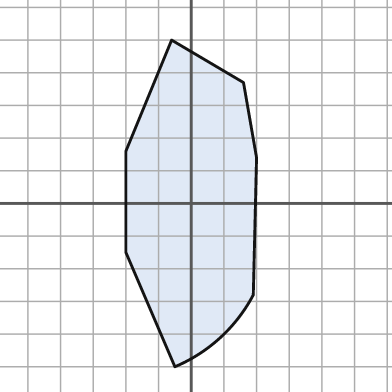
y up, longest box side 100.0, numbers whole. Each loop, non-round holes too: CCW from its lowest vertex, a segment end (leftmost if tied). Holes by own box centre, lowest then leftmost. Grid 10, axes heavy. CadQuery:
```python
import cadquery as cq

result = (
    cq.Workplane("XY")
    .moveTo(-5.0, -50.0)
    .threePointArc((9.0, -41.0), (19.0, -28.0))
    .lineTo(20.0, 14.0)
    .lineTo(16.0, 37.0)
    .lineTo(-6.0, 50.0)
    .lineTo(-20.0, 16.0)
    .lineTo(-20.0, -15.0)
    .close()
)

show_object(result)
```